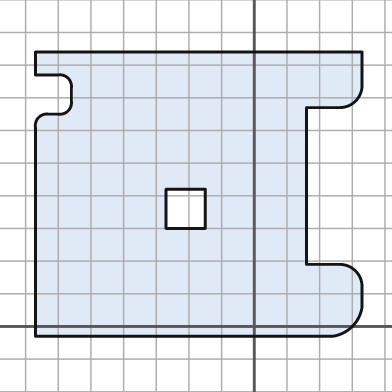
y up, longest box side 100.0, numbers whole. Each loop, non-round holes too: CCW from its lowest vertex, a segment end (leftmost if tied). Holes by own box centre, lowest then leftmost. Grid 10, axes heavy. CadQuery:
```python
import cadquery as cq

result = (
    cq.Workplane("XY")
    .moveTo(-67.0, -3.0)
    .lineTo(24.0, -3.0)
    .threePointArc((30.0, 0.0), (33.0, 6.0))
    .lineTo(33.0, 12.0)
    .threePointArc((31.0, 17.0), (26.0, 19.0))
    .lineTo(16.0, 19.0)
    .lineTo(16.0, 67.0)
    .lineTo(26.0, 67.0)
    .threePointArc((31.0, 69.0), (33.0, 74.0))
    .lineTo(33.0, 84.0)
    .lineTo(-67.0, 84.0)
    .lineTo(-67.0, 77.0)
    .lineTo(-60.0, 77.0)
    .threePointArc((-57.0, 76.0), (-56.0, 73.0))
    .lineTo(-56.0, 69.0)
    .threePointArc((-57.0, 66.0), (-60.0, 65.0))
    .lineTo(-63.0, 65.0)
    .threePointArc((-66.0, 64.0), (-67.0, 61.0))
    .close()
    .moveTo(-27.0, 30.0)
    .lineTo(-15.0, 30.0)
    .lineTo(-15.0, 42.0)
    .lineTo(-27.0, 42.0)
    .close()
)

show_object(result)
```